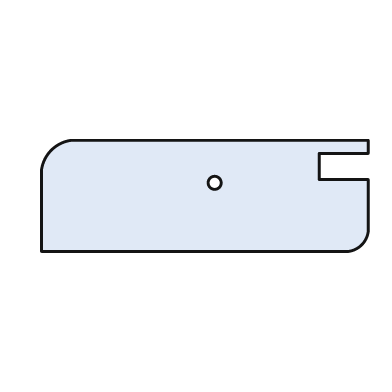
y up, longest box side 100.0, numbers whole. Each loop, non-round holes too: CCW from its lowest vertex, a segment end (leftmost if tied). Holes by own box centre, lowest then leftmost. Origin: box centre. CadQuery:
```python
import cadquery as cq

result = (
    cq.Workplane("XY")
    .moveTo(-50.0, -17.0)
    .lineTo(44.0, -17.0)
    .threePointArc((48.0, -15.0), (50.0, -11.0))
    .lineTo(50.0, 5.0)
    .lineTo(35.0, 5.0)
    .lineTo(35.0, 13.0)
    .lineTo(50.0, 13.0)
    .lineTo(50.0, 17.0)
    .lineTo(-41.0, 17.0)
    .threePointArc((-47.0, 14.0), (-50.0, 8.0))
    .close()
    .moveTo(3.0, 4.0)
    .circle(2.0)
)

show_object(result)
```